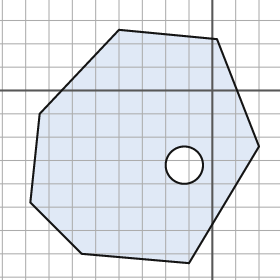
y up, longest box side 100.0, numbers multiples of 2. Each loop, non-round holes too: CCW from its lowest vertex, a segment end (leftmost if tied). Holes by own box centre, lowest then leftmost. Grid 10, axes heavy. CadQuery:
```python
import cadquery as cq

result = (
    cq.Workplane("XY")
    .moveTo(-10.0, -74.0)
    .lineTo(20.0, -24.0)
    .lineTo(2.0, 22.0)
    .lineTo(-40.0, 26.0)
    .lineTo(-74.0, -10.0)
    .lineTo(-78.0, -48.0)
    .lineTo(-56.0, -70.0)
    .close()
    .moveTo(-12.0, -32.0)
    .circle(8.0)
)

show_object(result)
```